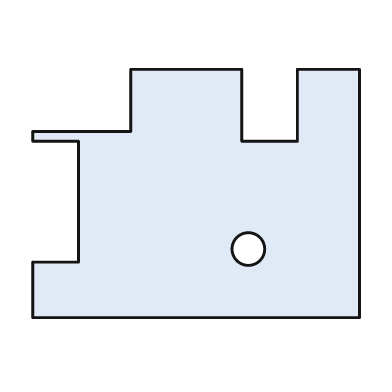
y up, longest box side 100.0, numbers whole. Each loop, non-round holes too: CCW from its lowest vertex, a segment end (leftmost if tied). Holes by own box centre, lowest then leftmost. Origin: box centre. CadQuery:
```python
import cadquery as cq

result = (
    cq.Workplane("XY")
    .moveTo(-50.0, -38.0)
    .lineTo(50.0, -38.0)
    .lineTo(50.0, 38.0)
    .lineTo(31.0, 38.0)
    .lineTo(31.0, 16.0)
    .lineTo(14.0, 16.0)
    .lineTo(14.0, 38.0)
    .lineTo(-20.0, 38.0)
    .lineTo(-20.0, 19.0)
    .lineTo(-50.0, 19.0)
    .lineTo(-50.0, 16.0)
    .lineTo(-36.0, 16.0)
    .lineTo(-36.0, -21.0)
    .lineTo(-50.0, -21.0)
    .close()
    .moveTo(16.0, -17.0)
    .circle(5.0)
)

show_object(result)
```